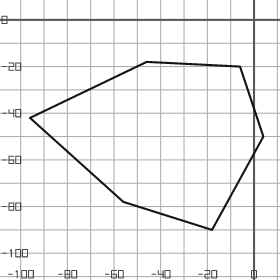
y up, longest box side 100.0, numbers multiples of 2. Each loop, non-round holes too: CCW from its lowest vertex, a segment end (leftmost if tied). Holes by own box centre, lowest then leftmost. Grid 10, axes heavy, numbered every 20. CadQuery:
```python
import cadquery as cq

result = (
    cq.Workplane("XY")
    .moveTo(-18.0, -90.0)
    .lineTo(4.0, -50.0)
    .lineTo(-6.0, -20.0)
    .lineTo(-46.0, -18.0)
    .lineTo(-96.0, -42.0)
    .lineTo(-56.0, -78.0)
    .close()
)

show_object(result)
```